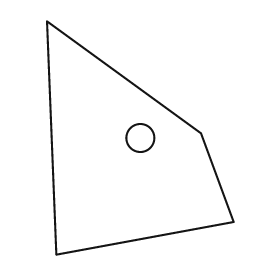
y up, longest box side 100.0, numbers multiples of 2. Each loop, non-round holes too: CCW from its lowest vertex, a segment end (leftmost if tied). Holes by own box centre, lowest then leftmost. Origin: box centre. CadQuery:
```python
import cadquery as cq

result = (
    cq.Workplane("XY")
    .moveTo(-36.0, -50.0)
    .lineTo(40.0, -36.0)
    .lineTo(26.0, 2.0)
    .lineTo(-40.0, 50.0)
    .close()
    .moveTo(0.0, 0.0)
    .circle(6.0)
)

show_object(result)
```